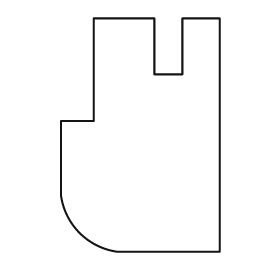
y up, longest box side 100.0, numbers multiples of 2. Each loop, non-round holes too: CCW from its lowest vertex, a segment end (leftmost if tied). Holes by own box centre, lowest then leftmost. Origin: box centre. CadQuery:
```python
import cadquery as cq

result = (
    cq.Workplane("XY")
    .moveTo(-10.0, -50.0)
    .lineTo(34.0, -50.0)
    .lineTo(34.0, 50.0)
    .lineTo(18.0, 50.0)
    .lineTo(18.0, 26.0)
    .lineTo(6.0, 26.0)
    .lineTo(6.0, 50.0)
    .lineTo(-20.0, 50.0)
    .lineTo(-20.0, 6.0)
    .lineTo(-34.0, 6.0)
    .lineTo(-34.0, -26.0)
    .threePointArc((-26.0, -42.0), (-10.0, -50.0))
    .close()
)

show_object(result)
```